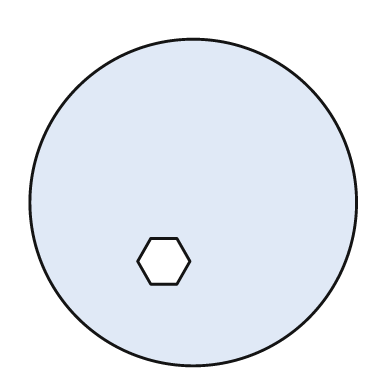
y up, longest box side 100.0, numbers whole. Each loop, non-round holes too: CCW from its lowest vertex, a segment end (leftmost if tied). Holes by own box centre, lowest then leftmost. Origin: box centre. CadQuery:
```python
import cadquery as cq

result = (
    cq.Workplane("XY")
    .moveTo(0.0, 0.0)
    .circle(50.0)
    .moveTo(-13.0, -25.0)
    .lineTo(-5.0, -25.0)
    .lineTo(-1.0, -18.0)
    .lineTo(-5.0, -11.0)
    .lineTo(-13.0, -11.0)
    .lineTo(-17.0, -18.0)
    .close()
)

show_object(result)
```